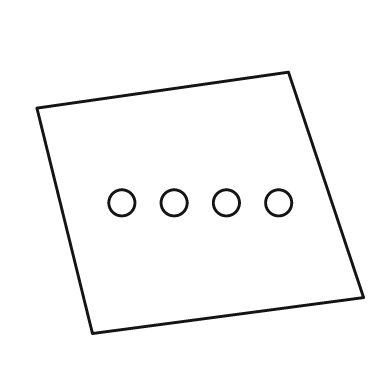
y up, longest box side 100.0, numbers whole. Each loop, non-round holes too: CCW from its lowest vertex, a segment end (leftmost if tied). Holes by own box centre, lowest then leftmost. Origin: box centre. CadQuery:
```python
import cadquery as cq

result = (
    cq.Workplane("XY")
    .moveTo(-33.0, -40.0)
    .lineTo(50.0, -29.0)
    .lineTo(27.0, 40.0)
    .lineTo(-50.0, 29.0)
    .close()
    .moveTo(-24.0, 0.0)
    .circle(4.0)
    .moveTo(-8.0, 0.0)
    .circle(4.0)
    .moveTo(8.0, 0.0)
    .circle(4.0)
    .moveTo(24.0, 0.0)
    .circle(4.0)
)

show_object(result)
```